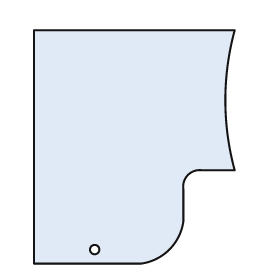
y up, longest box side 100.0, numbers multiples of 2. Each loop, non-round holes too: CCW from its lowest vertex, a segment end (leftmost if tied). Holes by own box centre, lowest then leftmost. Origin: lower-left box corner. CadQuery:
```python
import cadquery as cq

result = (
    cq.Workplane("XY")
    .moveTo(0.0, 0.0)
    .lineTo(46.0, 0.0)
    .threePointArc((58.0, 6.0), (64.0, 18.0))
    .lineTo(64.0, 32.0)
    .threePointArc((66.0, 38.0), (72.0, 40.0))
    .lineTo(86.0, 40.0)
    .threePointArc((82.0, 70.0), (86.0, 100.0))
    .lineTo(0.0, 100.0)
    .close()
    .moveTo(26.0, 6.0)
    .circle(2.0)
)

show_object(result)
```